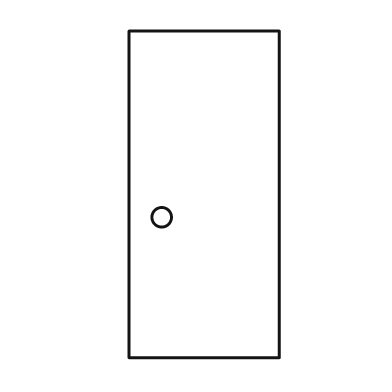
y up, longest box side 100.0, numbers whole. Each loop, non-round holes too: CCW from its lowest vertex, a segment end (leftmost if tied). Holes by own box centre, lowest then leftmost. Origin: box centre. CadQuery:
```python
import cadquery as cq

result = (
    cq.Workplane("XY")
    .moveTo(-23.0, -50.0)
    .lineTo(23.0, -50.0)
    .lineTo(23.0, 50.0)
    .lineTo(-23.0, 50.0)
    .close()
    .moveTo(-13.0, -7.0)
    .circle(3.0)
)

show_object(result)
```